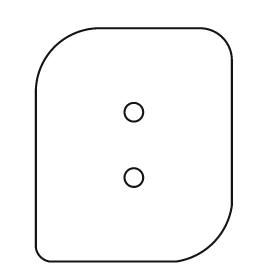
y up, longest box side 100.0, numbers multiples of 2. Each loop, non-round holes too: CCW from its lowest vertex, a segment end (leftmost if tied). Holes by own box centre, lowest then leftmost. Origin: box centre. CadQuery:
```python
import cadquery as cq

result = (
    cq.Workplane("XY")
    .moveTo(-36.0, -50.0)
    .lineTo(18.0, -50.0)
    .threePointArc((34.0, -42.0), (42.0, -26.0))
    .lineTo(42.0, 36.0)
    .threePointArc((38.0, 46.0), (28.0, 50.0))
    .lineTo(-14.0, 50.0)
    .threePointArc((-34.0, 42.0), (-42.0, 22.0))
    .lineTo(-42.0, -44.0)
    .threePointArc((-40.0, -48.0), (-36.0, -50.0))
    .close()
    .moveTo(0.0, -14.0)
    .circle(4.0)
    .moveTo(0.0, 14.0)
    .circle(4.0)
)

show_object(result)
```